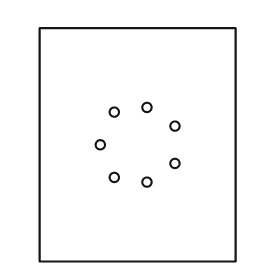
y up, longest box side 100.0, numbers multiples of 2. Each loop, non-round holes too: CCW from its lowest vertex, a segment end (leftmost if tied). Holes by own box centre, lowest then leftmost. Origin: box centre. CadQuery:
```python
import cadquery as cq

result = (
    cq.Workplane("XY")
    .moveTo(-42.0, -50.0)
    .lineTo(42.0, -50.0)
    .lineTo(42.0, 50.0)
    .lineTo(-42.0, 50.0)
    .close()
    .moveTo(4.0, -16.0)
    .circle(2.0)
    .moveTo(-10.0, -14.0)
    .circle(2.0)
    .moveTo(16.0, -8.0)
    .circle(2.0)
    .moveTo(-16.0, 0.0)
    .circle(2.0)
    .moveTo(16.0, 8.0)
    .circle(2.0)
    .moveTo(-10.0, 14.0)
    .circle(2.0)
    .moveTo(4.0, 16.0)
    .circle(2.0)
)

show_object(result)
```